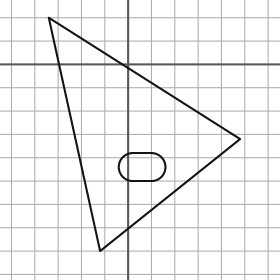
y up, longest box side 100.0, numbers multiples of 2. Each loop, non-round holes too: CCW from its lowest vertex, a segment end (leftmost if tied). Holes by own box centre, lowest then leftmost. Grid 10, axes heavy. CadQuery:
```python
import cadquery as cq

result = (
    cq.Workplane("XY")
    .moveTo(-12.0, -80.0)
    .lineTo(48.0, -32.0)
    .lineTo(-34.0, 20.0)
    .close()
    .moveTo(2.0, -50.0)
    .lineTo(10.0, -50.0)
    .threePointArc((16.0, -44.0), (10.0, -38.0))
    .lineTo(2.0, -38.0)
    .threePointArc((-4.0, -44.0), (2.0, -50.0))
    .close()
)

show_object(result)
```